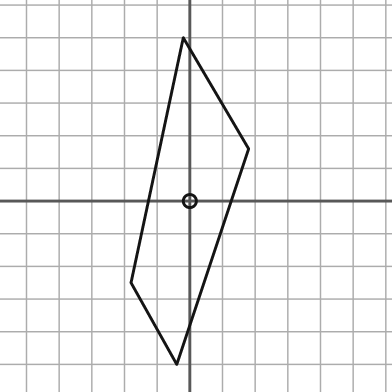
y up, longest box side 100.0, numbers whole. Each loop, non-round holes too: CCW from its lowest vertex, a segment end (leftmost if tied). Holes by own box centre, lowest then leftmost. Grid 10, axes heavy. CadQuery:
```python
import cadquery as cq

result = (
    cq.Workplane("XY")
    .moveTo(-4.0, -50.0)
    .lineTo(18.0, 16.0)
    .lineTo(-2.0, 50.0)
    .lineTo(-18.0, -25.0)
    .close()
    .moveTo(0.0, 0.0)
    .circle(2.0)
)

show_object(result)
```